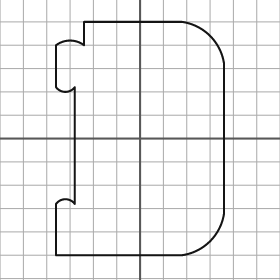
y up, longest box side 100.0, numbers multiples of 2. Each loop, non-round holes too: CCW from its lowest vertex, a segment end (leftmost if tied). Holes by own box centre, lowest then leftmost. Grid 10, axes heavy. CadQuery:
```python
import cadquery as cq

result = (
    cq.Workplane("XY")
    .moveTo(-36.0, -50.0)
    .lineTo(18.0, -50.0)
    .threePointArc((30.0, -44.0), (36.0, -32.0))
    .lineTo(36.0, 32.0)
    .threePointArc((30.0, 44.0), (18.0, 50.0))
    .lineTo(-24.0, 50.0)
    .lineTo(-24.0, 40.0)
    .threePointArc((-30.0, 42.0), (-36.0, 40.0))
    .lineTo(-36.0, 22.0)
    .threePointArc((-32.0, 20.0), (-28.0, 22.0))
    .lineTo(-28.0, -28.0)
    .threePointArc((-32.0, -26.0), (-36.0, -28.0))
    .close()
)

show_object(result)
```